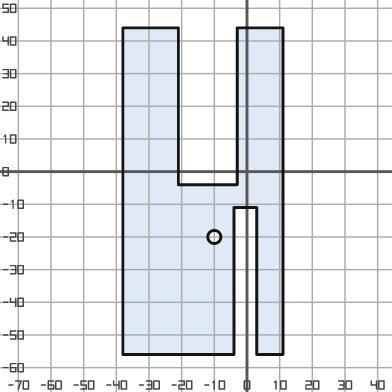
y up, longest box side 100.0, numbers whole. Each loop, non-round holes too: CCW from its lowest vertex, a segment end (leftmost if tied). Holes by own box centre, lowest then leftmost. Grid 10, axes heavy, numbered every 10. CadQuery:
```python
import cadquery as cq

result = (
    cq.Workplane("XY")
    .moveTo(-38.0, -56.0)
    .lineTo(-4.0, -56.0)
    .lineTo(-4.0, -11.0)
    .lineTo(3.0, -11.0)
    .lineTo(3.0, -56.0)
    .lineTo(11.0, -56.0)
    .lineTo(11.0, 44.0)
    .lineTo(-3.0, 44.0)
    .lineTo(-3.0, -4.0)
    .lineTo(-21.0, -4.0)
    .lineTo(-21.0, 44.0)
    .lineTo(-38.0, 44.0)
    .close()
    .moveTo(-10.0, -20.0)
    .circle(2.0)
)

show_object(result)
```